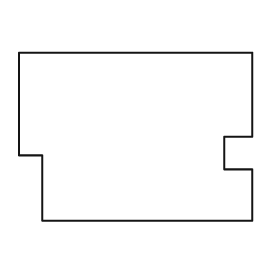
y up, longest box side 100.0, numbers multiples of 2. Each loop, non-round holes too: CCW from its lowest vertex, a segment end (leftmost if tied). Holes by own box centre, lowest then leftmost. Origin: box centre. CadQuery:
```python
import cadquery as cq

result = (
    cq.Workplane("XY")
    .moveTo(-40.0, -36.0)
    .lineTo(50.0, -36.0)
    .lineTo(50.0, -14.0)
    .lineTo(38.0, -14.0)
    .lineTo(38.0, 0.0)
    .lineTo(50.0, 0.0)
    .lineTo(50.0, 36.0)
    .lineTo(-50.0, 36.0)
    .lineTo(-50.0, -8.0)
    .lineTo(-40.0, -8.0)
    .close()
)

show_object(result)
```